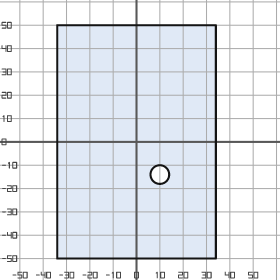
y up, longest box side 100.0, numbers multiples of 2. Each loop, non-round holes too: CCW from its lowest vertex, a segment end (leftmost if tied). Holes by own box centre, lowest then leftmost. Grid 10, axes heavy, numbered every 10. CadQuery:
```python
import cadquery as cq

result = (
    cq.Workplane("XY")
    .moveTo(-34.0, -50.0)
    .lineTo(34.0, -50.0)
    .lineTo(34.0, 50.0)
    .lineTo(-34.0, 50.0)
    .close()
    .moveTo(10.0, -14.0)
    .circle(4.0)
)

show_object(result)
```